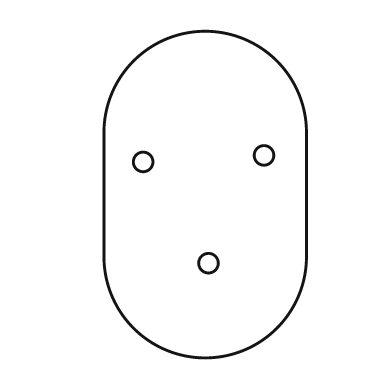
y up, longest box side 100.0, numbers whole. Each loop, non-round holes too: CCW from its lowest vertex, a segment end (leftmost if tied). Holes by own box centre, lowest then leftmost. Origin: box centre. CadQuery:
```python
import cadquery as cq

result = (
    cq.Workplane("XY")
    .moveTo(-31.0, -19.0)
    .threePointArc((0.0, -50.0), (31.0, -19.0))
    .lineTo(31.0, 19.0)
    .threePointArc((0.0, 50.0), (-31.0, 19.0))
    .close()
    .moveTo(1.0, -21.0)
    .circle(3.0)
    .moveTo(-19.0, 10.0)
    .circle(3.0)
    .moveTo(18.0, 12.0)
    .circle(3.0)
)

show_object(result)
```